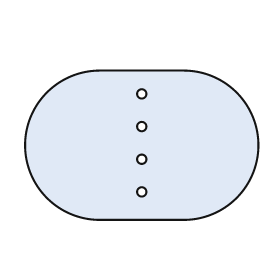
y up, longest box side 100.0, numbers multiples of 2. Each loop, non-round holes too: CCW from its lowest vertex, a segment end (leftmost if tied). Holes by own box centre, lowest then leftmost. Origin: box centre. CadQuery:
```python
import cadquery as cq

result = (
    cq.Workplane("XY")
    .moveTo(-18.0, -32.0)
    .lineTo(18.0, -32.0)
    .threePointArc((50.0, 0.0), (18.0, 32.0))
    .lineTo(-18.0, 32.0)
    .threePointArc((-50.0, 0.0), (-18.0, -32.0))
    .close()
    .moveTo(0.0, -20.0)
    .circle(2.0)
    .moveTo(0.0, -6.0)
    .circle(2.0)
    .moveTo(0.0, 8.0)
    .circle(2.0)
    .moveTo(0.0, 22.0)
    .circle(2.0)
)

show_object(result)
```